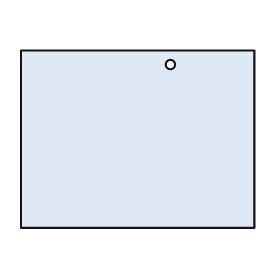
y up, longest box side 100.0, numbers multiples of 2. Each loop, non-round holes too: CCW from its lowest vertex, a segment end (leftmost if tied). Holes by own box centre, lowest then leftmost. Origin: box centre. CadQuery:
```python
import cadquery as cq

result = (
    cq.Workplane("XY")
    .moveTo(-50.0, -38.0)
    .lineTo(50.0, -38.0)
    .lineTo(50.0, 38.0)
    .lineTo(-50.0, 38.0)
    .close()
    .moveTo(14.0, 32.0)
    .circle(2.0)
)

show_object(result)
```